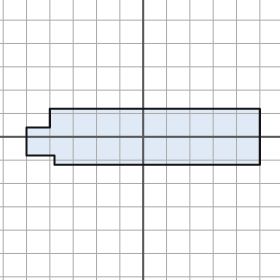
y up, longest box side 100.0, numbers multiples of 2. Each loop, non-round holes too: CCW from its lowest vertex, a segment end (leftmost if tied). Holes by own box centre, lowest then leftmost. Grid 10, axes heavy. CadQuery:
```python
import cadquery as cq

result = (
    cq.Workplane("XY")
    .moveTo(-38.0, -12.0)
    .lineTo(50.0, -12.0)
    .lineTo(50.0, 12.0)
    .lineTo(-40.0, 12.0)
    .lineTo(-40.0, 4.0)
    .lineTo(-50.0, 4.0)
    .lineTo(-50.0, -8.0)
    .lineTo(-38.0, -8.0)
    .close()
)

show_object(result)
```